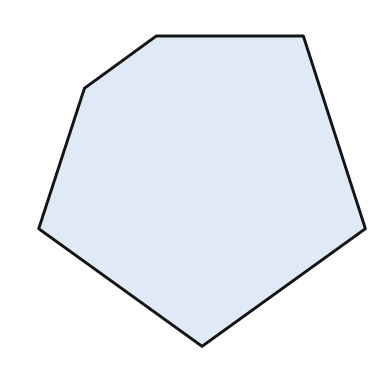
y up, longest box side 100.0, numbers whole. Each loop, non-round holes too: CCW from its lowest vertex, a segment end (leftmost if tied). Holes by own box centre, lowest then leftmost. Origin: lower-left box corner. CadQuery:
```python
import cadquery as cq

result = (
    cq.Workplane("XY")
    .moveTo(50.0, 0.0)
    .lineTo(100.0, 36.0)
    .lineTo(81.0, 95.0)
    .lineTo(36.0, 95.0)
    .lineTo(14.0, 79.0)
    .lineTo(0.0, 36.0)
    .close()
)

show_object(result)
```